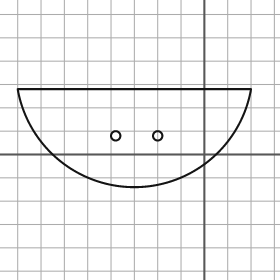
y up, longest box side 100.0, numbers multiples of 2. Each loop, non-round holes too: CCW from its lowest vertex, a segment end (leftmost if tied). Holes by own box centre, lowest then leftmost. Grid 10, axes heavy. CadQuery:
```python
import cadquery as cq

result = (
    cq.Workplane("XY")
    .moveTo(-80.0, 28.0)
    .threePointArc((-30.0, -14.0), (20.0, 28.0))
    .close()
    .moveTo(-38.0, 8.0)
    .circle(2.0)
    .moveTo(-20.0, 8.0)
    .circle(2.0)
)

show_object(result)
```